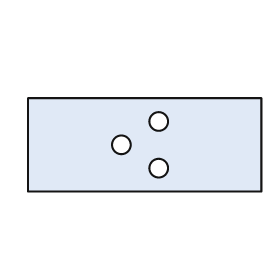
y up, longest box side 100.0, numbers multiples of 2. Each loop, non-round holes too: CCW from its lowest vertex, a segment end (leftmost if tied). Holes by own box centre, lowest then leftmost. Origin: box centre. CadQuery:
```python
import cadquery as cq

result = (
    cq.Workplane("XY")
    .moveTo(-50.0, -20.0)
    .lineTo(50.0, -20.0)
    .lineTo(50.0, 20.0)
    .lineTo(-50.0, 20.0)
    .close()
    .moveTo(6.0, -10.0)
    .circle(4.0)
    .moveTo(-10.0, 0.0)
    .circle(4.0)
    .moveTo(6.0, 10.0)
    .circle(4.0)
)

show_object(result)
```